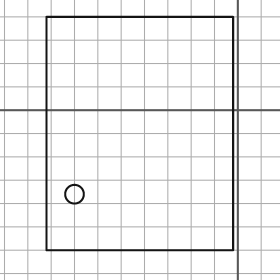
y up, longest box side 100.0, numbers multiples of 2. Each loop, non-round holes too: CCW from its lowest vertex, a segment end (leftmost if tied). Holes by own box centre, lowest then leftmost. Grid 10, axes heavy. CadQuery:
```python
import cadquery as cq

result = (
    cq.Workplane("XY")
    .moveTo(-82.0, -60.0)
    .lineTo(-2.0, -60.0)
    .lineTo(-2.0, 40.0)
    .lineTo(-82.0, 40.0)
    .close()
    .moveTo(-70.0, -36.0)
    .circle(4.0)
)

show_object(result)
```